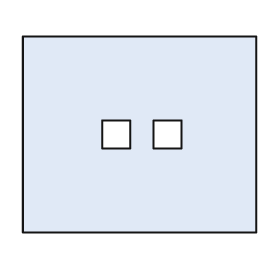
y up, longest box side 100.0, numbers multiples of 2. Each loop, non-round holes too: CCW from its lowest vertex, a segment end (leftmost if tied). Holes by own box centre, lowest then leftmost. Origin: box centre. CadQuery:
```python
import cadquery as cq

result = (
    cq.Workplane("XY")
    .moveTo(-50.0, -42.0)
    .lineTo(50.0, -42.0)
    .lineTo(50.0, 42.0)
    .lineTo(-50.0, 42.0)
    .close()
    .moveTo(-16.0, -6.0)
    .lineTo(-4.0, -6.0)
    .lineTo(-4.0, 6.0)
    .lineTo(-16.0, 6.0)
    .close()
    .moveTo(6.0, -6.0)
    .lineTo(18.0, -6.0)
    .lineTo(18.0, 6.0)
    .lineTo(6.0, 6.0)
    .close()
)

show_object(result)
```